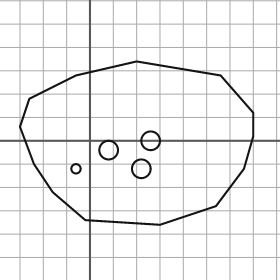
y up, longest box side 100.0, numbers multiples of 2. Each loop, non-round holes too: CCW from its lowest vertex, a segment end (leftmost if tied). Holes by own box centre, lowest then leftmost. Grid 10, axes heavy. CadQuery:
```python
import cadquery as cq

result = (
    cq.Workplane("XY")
    .moveTo(30.0, -36.0)
    .lineTo(54.0, -28.0)
    .lineTo(66.0, -12.0)
    .lineTo(70.0, 2.0)
    .lineTo(70.0, 12.0)
    .lineTo(56.0, 28.0)
    .lineTo(20.0, 34.0)
    .lineTo(-6.0, 28.0)
    .lineTo(-26.0, 18.0)
    .lineTo(-30.0, 6.0)
    .lineTo(-24.0, -10.0)
    .lineTo(-16.0, -22.0)
    .lineTo(-2.0, -34.0)
    .close()
    .moveTo(-6.0, -12.0)
    .circle(2.0)
    .moveTo(22.0, -12.0)
    .circle(4.0)
    .moveTo(8.0, -4.0)
    .circle(4.0)
    .moveTo(26.0, 0.0)
    .circle(4.0)
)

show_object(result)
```